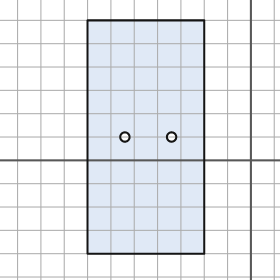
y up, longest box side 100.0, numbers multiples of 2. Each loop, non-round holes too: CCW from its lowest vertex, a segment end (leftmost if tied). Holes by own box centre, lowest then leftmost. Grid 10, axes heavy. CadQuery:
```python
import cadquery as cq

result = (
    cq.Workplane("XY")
    .moveTo(-70.0, -40.0)
    .lineTo(-20.0, -40.0)
    .lineTo(-20.0, 60.0)
    .lineTo(-70.0, 60.0)
    .close()
    .moveTo(-54.0, 10.0)
    .circle(2.0)
    .moveTo(-34.0, 10.0)
    .circle(2.0)
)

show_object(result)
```